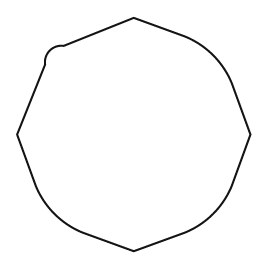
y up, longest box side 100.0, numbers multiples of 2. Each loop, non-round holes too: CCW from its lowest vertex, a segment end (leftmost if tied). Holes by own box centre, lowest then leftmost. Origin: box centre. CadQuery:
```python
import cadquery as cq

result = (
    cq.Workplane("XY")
    .moveTo(0.0, -50.0)
    .lineTo(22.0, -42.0)
    .threePointArc((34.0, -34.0), (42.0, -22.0))
    .lineTo(50.0, 0.0)
    .lineTo(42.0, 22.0)
    .threePointArc((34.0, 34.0), (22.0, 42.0))
    .lineTo(0.0, 50.0)
    .lineTo(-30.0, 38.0)
    .threePointArc((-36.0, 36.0), (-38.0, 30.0))
    .lineTo(-50.0, 0.0)
    .lineTo(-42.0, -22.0)
    .threePointArc((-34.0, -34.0), (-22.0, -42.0))
    .close()
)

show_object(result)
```